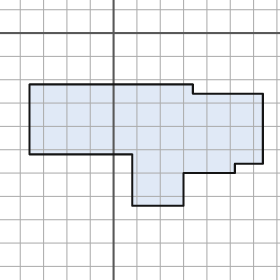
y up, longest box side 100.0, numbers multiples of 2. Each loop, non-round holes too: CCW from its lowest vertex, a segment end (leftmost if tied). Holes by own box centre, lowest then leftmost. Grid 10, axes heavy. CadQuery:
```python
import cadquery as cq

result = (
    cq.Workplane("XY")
    .moveTo(8.0, -74.0)
    .lineTo(30.0, -74.0)
    .lineTo(30.0, -60.0)
    .lineTo(52.0, -60.0)
    .lineTo(52.0, -56.0)
    .lineTo(64.0, -56.0)
    .lineTo(64.0, -26.0)
    .lineTo(34.0, -26.0)
    .lineTo(34.0, -22.0)
    .lineTo(-36.0, -22.0)
    .lineTo(-36.0, -52.0)
    .lineTo(8.0, -52.0)
    .close()
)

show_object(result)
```